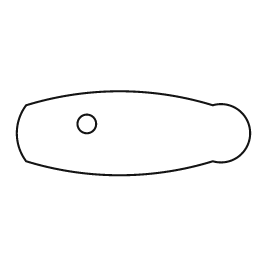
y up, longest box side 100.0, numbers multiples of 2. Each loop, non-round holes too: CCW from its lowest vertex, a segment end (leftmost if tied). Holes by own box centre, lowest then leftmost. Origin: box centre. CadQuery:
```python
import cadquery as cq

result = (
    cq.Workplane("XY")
    .moveTo(-46.0, -12.0)
    .threePointArc((-6.0, -18.0), (34.0, -12.0))
    .threePointArc((50.0, 0.0), (34.0, 12.0))
    .threePointArc((-6.0, 18.0), (-46.0, 12.0))
    .threePointArc((-50.0, 0.0), (-46.0, -12.0))
    .close()
    .moveTo(-20.0, 4.0)
    .circle(4.0)
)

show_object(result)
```